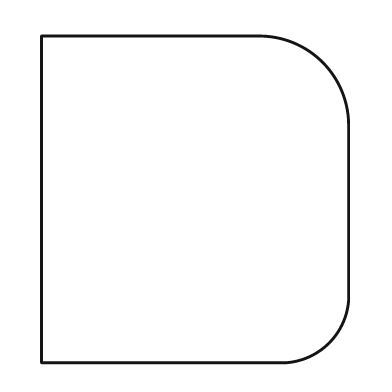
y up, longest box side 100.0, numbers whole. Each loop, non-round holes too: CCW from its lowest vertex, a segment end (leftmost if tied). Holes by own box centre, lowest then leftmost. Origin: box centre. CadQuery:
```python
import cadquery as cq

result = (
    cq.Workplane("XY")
    .moveTo(-47.0, -50.0)
    .lineTo(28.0, -50.0)
    .threePointArc((41.0, -44.0), (47.0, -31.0))
    .lineTo(47.0, 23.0)
    .threePointArc((39.0, 42.0), (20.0, 50.0))
    .lineTo(-47.0, 50.0)
    .close()
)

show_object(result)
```